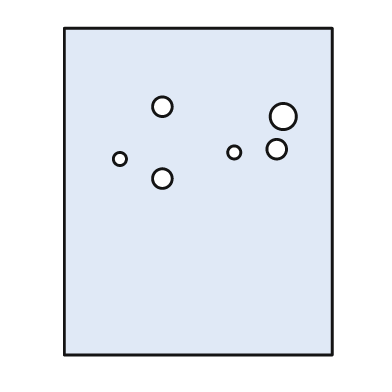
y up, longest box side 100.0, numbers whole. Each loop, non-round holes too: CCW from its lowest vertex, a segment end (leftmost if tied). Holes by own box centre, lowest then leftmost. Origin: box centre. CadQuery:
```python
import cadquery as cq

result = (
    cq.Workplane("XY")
    .moveTo(-41.0, -50.0)
    .lineTo(41.0, -50.0)
    .lineTo(41.0, 50.0)
    .lineTo(-41.0, 50.0)
    .close()
    .moveTo(-11.0, 4.0)
    .circle(3.0)
    .moveTo(-24.0, 10.0)
    .circle(2.0)
    .moveTo(11.0, 12.0)
    .circle(2.0)
    .moveTo(24.0, 13.0)
    .circle(3.0)
    .moveTo(26.0, 23.0)
    .circle(4.0)
    .moveTo(-11.0, 26.0)
    .circle(3.0)
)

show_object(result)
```